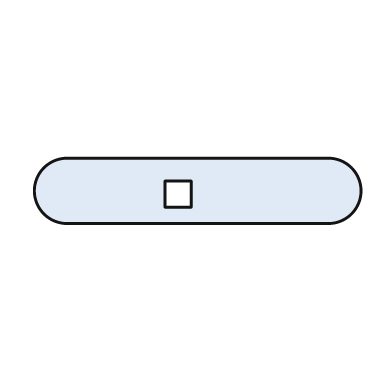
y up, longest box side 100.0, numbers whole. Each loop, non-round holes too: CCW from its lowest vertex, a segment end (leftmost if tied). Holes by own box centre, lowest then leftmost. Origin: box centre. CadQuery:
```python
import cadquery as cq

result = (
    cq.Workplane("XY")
    .moveTo(-40.0, -10.0)
    .lineTo(40.0, -10.0)
    .threePointArc((50.0, 0.0), (40.0, 10.0))
    .lineTo(-40.0, 10.0)
    .threePointArc((-50.0, 0.0), (-40.0, -10.0))
    .close()
    .moveTo(-10.0, -5.0)
    .lineTo(-2.0, -5.0)
    .lineTo(-2.0, 3.0)
    .lineTo(-10.0, 3.0)
    .close()
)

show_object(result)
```